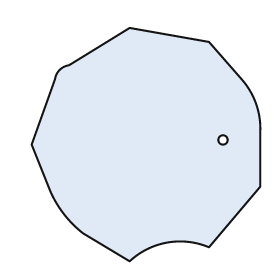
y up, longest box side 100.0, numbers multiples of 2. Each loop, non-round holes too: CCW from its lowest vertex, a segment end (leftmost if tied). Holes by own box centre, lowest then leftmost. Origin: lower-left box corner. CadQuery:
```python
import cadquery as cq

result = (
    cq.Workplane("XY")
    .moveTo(42.0, 0.0)
    .threePointArc((58.0, 8.0), (76.0, 6.0))
    .lineTo(98.0, 32.0)
    .lineTo(98.0, 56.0)
    .threePointArc((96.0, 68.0), (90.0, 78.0))
    .lineTo(76.0, 94.0)
    .lineTo(42.0, 100.0)
    .lineTo(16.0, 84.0)
    .threePointArc((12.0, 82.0), (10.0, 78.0))
    .lineTo(0.0, 50.0)
    .lineTo(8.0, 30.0)
    .threePointArc((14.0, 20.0), (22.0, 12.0))
    .close()
    .moveTo(82.0, 52.0)
    .circle(2.0)
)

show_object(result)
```